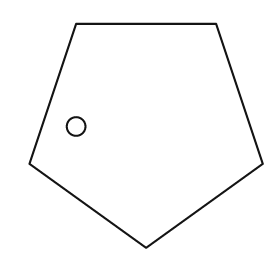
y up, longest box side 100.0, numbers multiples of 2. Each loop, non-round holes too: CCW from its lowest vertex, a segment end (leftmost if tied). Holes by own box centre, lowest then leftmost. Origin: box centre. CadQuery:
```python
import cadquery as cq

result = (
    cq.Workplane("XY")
    .moveTo(0.0, -48.0)
    .lineTo(50.0, -12.0)
    .lineTo(30.0, 48.0)
    .lineTo(-30.0, 48.0)
    .lineTo(-50.0, -12.0)
    .close()
    .moveTo(-30.0, 4.0)
    .circle(4.0)
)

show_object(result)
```